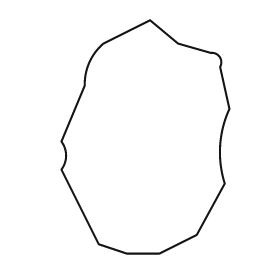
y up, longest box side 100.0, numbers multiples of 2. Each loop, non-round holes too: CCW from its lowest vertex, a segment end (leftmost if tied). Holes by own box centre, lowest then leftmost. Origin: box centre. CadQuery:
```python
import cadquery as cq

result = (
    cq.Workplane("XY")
    .moveTo(-8.0, -50.0)
    .lineTo(6.0, -50.0)
    .lineTo(22.0, -42.0)
    .lineTo(34.0, -20.0)
    .threePointArc((32.0, -4.0), (36.0, 12.0))
    .lineTo(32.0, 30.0)
    .threePointArc((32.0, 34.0), (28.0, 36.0))
    .lineTo(14.0, 40.0)
    .lineTo(2.0, 50.0)
    .lineTo(-18.0, 40.0)
    .threePointArc((-24.0, 32.0), (-26.0, 22.0))
    .lineTo(-36.0, -2.0)
    .threePointArc((-34.0, -8.0), (-36.0, -14.0))
    .lineTo(-20.0, -46.0)
    .close()
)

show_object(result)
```